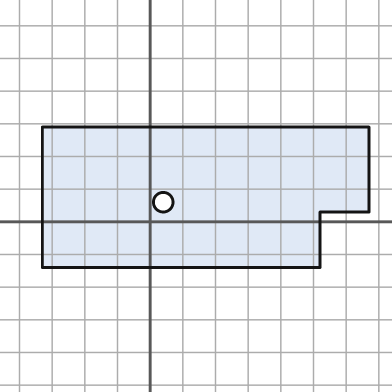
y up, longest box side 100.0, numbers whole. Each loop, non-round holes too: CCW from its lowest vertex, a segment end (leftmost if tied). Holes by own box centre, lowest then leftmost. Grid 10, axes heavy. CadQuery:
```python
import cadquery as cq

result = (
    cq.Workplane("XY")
    .moveTo(-33.0, -14.0)
    .lineTo(52.0, -14.0)
    .lineTo(52.0, 3.0)
    .lineTo(67.0, 3.0)
    .lineTo(67.0, 29.0)
    .lineTo(-33.0, 29.0)
    .close()
    .moveTo(4.0, 6.0)
    .circle(3.0)
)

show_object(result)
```